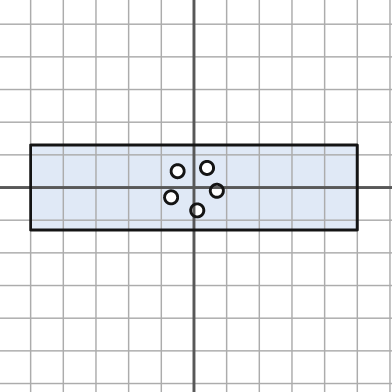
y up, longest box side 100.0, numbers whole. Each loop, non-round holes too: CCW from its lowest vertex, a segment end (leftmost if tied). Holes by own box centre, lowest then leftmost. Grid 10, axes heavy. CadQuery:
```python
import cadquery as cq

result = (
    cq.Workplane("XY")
    .moveTo(-50.0, -13.0)
    .lineTo(50.0, -13.0)
    .lineTo(50.0, 13.0)
    .lineTo(-50.0, 13.0)
    .close()
    .moveTo(1.0, -7.0)
    .circle(2.0)
    .moveTo(-7.0, -3.0)
    .circle(2.0)
    .moveTo(7.0, -1.0)
    .circle(2.0)
    .moveTo(-5.0, 5.0)
    .circle(2.0)
    .moveTo(4.0, 6.0)
    .circle(2.0)
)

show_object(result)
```